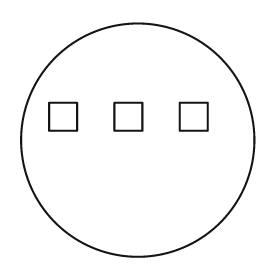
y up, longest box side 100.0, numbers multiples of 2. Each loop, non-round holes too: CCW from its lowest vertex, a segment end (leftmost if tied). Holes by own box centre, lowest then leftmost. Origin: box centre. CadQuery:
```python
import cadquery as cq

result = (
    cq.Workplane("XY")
    .moveTo(0.0, 0.0)
    .circle(50.0)
    .moveTo(-38.0, 4.0)
    .lineTo(-26.0, 4.0)
    .lineTo(-26.0, 16.0)
    .lineTo(-38.0, 16.0)
    .close()
    .moveTo(-10.0, 4.0)
    .lineTo(2.0, 4.0)
    .lineTo(2.0, 16.0)
    .lineTo(-10.0, 16.0)
    .close()
    .moveTo(18.0, 4.0)
    .lineTo(30.0, 4.0)
    .lineTo(30.0, 16.0)
    .lineTo(18.0, 16.0)
    .close()
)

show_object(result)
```